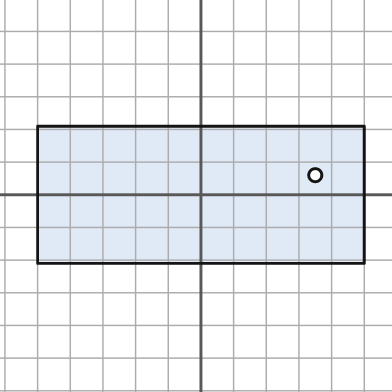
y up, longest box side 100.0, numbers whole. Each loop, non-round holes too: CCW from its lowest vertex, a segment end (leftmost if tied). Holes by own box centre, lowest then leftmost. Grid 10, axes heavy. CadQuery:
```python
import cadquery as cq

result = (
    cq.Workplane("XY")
    .moveTo(-50.0, -21.0)
    .lineTo(50.0, -21.0)
    .lineTo(50.0, 21.0)
    .lineTo(-50.0, 21.0)
    .close()
    .moveTo(35.0, 6.0)
    .circle(2.0)
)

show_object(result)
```